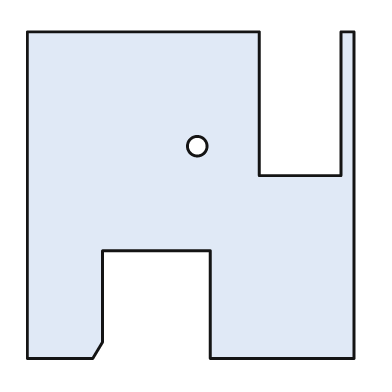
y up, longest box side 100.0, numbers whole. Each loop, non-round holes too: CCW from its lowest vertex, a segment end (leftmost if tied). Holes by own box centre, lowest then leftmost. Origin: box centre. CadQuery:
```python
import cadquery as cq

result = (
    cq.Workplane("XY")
    .moveTo(-50.0, -50.0)
    .lineTo(-30.0, -50.0)
    .lineTo(-27.0, -45.0)
    .lineTo(-27.0, -17.0)
    .lineTo(6.0, -17.0)
    .lineTo(6.0, -50.0)
    .lineTo(50.0, -50.0)
    .lineTo(50.0, 50.0)
    .lineTo(46.0, 50.0)
    .lineTo(46.0, 6.0)
    .lineTo(21.0, 6.0)
    .lineTo(21.0, 50.0)
    .lineTo(-50.0, 50.0)
    .close()
    .moveTo(2.0, 15.0)
    .circle(3.0)
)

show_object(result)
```